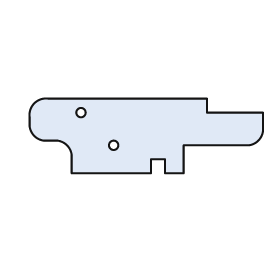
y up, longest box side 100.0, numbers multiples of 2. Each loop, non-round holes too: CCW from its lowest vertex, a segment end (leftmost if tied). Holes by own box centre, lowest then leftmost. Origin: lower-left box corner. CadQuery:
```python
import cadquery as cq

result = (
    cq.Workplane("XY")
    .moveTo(18.0, 0.0)
    .lineTo(52.0, 0.0)
    .lineTo(52.0, 6.0)
    .lineTo(58.0, 6.0)
    .lineTo(58.0, 0.0)
    .lineTo(66.0, 0.0)
    .lineTo(66.0, 12.0)
    .lineTo(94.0, 12.0)
    .threePointArc((98.0, 14.0), (100.0, 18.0))
    .lineTo(100.0, 26.0)
    .lineTo(76.0, 26.0)
    .lineTo(76.0, 32.0)
    .lineTo(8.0, 32.0)
    .threePointArc((2.0, 30.0), (0.0, 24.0))
    .lineTo(0.0, 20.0)
    .threePointArc((2.0, 16.0), (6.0, 14.0))
    .lineTo(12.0, 14.0)
    .threePointArc((16.0, 12.0), (18.0, 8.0))
    .close()
    .moveTo(36.0, 12.0)
    .circle(2.0)
    .moveTo(22.0, 26.0)
    .circle(2.0)
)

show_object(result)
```